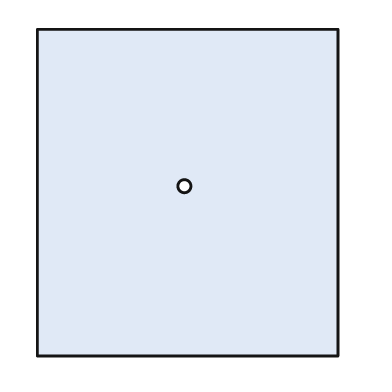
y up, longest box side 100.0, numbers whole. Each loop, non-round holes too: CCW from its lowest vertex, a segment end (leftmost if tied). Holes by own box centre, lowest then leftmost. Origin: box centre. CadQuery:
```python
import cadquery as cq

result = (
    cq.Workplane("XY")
    .moveTo(-46.0, -50.0)
    .lineTo(46.0, -50.0)
    .lineTo(46.0, 50.0)
    .lineTo(-46.0, 50.0)
    .close()
    .moveTo(-1.0, 2.0)
    .circle(2.0)
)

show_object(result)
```